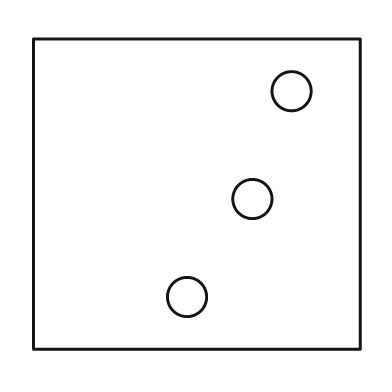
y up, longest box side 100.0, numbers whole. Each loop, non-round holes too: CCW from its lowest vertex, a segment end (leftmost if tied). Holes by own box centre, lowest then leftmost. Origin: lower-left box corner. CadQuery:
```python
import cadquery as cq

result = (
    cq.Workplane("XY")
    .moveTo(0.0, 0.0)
    .lineTo(100.0, 0.0)
    .lineTo(100.0, 95.0)
    .lineTo(0.0, 95.0)
    .close()
    .moveTo(47.0, 16.0)
    .circle(6.0)
    .moveTo(67.0, 46.0)
    .circle(6.0)
    .moveTo(79.0, 79.0)
    .circle(6.0)
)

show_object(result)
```